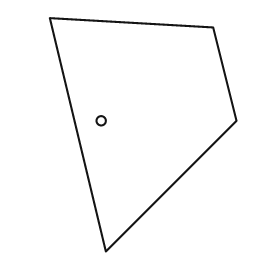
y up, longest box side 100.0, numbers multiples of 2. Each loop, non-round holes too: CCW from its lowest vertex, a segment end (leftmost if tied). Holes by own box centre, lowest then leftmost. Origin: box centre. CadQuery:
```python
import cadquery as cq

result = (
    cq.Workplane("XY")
    .moveTo(-16.0, -50.0)
    .lineTo(40.0, 6.0)
    .lineTo(30.0, 46.0)
    .lineTo(-40.0, 50.0)
    .close()
    .moveTo(-18.0, 6.0)
    .circle(2.0)
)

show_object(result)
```